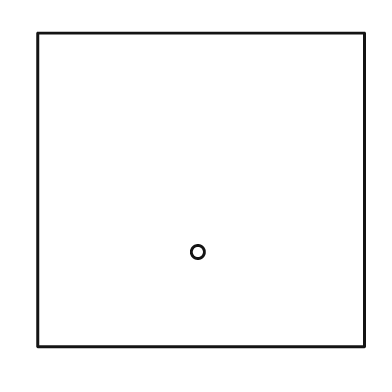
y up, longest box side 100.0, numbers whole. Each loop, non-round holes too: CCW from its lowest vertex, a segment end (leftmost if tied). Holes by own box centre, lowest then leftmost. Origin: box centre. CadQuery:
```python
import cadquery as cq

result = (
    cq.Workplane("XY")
    .moveTo(-50.0, -48.0)
    .lineTo(50.0, -48.0)
    .lineTo(50.0, 48.0)
    .lineTo(-50.0, 48.0)
    .close()
    .moveTo(-1.0, -19.0)
    .circle(2.0)
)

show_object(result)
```